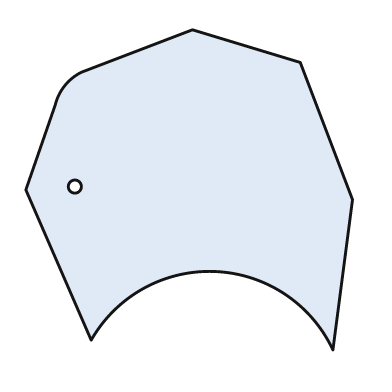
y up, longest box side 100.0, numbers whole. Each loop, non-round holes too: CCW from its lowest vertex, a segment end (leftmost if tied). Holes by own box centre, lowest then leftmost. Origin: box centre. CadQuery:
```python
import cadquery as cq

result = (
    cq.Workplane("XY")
    .moveTo(44.0, -49.0)
    .lineTo(50.0, -3.0)
    .lineTo(34.0, 39.0)
    .lineTo(1.0, 49.0)
    .lineTo(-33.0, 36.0)
    .threePointArc((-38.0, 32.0), (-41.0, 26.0))
    .lineTo(-50.0, 0.0)
    .lineTo(-30.0, -46.0)
    .threePointArc((8.0, -25.0), (44.0, -49.0))
    .close()
    .moveTo(-35.0, 1.0)
    .circle(2.0)
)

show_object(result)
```